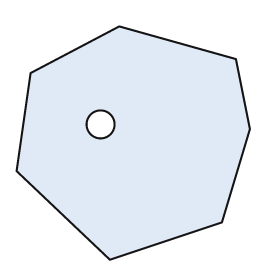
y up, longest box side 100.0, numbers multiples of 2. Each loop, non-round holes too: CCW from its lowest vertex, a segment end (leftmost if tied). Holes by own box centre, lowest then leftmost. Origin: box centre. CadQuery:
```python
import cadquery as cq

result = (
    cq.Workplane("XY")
    .moveTo(-10.0, -50.0)
    .lineTo(38.0, -34.0)
    .lineTo(50.0, 6.0)
    .lineTo(44.0, 36.0)
    .lineTo(-6.0, 50.0)
    .lineTo(-44.0, 30.0)
    .lineTo(-50.0, -12.0)
    .close()
    .moveTo(-14.0, 8.0)
    .circle(6.0)
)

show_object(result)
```